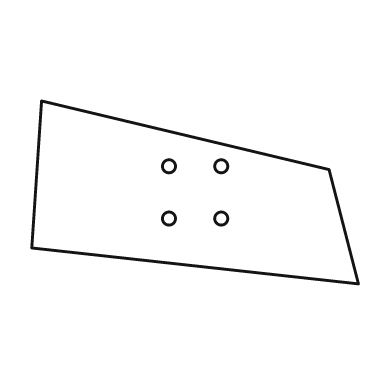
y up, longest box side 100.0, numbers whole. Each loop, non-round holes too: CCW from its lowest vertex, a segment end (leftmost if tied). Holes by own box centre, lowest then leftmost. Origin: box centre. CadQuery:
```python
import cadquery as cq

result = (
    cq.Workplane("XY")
    .moveTo(50.0, -28.0)
    .lineTo(41.0, 7.0)
    .lineTo(-47.0, 28.0)
    .lineTo(-50.0, -17.0)
    .close()
    .moveTo(-8.0, -8.0)
    .circle(2.0)
    .moveTo(8.0, -8.0)
    .circle(2.0)
    .moveTo(-8.0, 8.0)
    .circle(2.0)
    .moveTo(8.0, 8.0)
    .circle(2.0)
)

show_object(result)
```